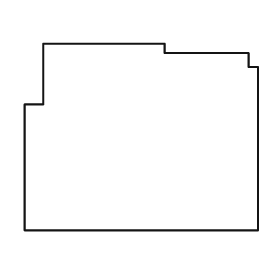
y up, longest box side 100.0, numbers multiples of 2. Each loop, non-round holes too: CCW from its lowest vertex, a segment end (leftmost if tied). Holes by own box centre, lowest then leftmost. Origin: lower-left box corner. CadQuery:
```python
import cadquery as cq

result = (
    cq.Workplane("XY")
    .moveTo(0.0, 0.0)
    .lineTo(100.0, 0.0)
    .lineTo(100.0, 70.0)
    .lineTo(96.0, 70.0)
    .lineTo(96.0, 76.0)
    .lineTo(60.0, 76.0)
    .lineTo(60.0, 80.0)
    .lineTo(8.0, 80.0)
    .lineTo(8.0, 54.0)
    .lineTo(0.0, 54.0)
    .close()
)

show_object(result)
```